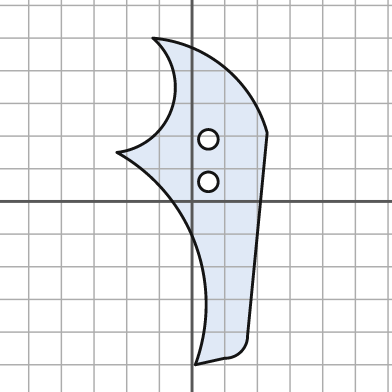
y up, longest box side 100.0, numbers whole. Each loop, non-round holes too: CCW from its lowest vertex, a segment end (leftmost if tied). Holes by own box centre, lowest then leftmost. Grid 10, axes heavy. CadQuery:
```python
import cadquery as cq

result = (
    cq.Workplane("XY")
    .moveTo(1.0, -50.0)
    .lineTo(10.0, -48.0)
    .threePointArc((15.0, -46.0), (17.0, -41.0))
    .lineTo(23.0, 21.0)
    .threePointArc((10.0, 41.0), (-12.0, 50.0))
    .threePointArc((-6.0, 29.0), (-23.0, 15.0))
    .threePointArc((1.0, -13.0), (1.0, -50.0))
    .close()
    .moveTo(5.0, 6.0)
    .circle(3.0)
    .moveTo(5.0, 19.0)
    .circle(3.0)
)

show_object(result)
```